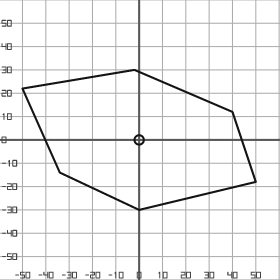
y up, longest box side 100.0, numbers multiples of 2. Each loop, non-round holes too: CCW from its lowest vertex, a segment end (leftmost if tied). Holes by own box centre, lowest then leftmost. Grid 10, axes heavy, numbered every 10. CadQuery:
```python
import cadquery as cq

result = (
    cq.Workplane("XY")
    .moveTo(0.0, -30.0)
    .lineTo(50.0, -18.0)
    .lineTo(40.0, 12.0)
    .lineTo(-2.0, 30.0)
    .lineTo(-50.0, 22.0)
    .lineTo(-34.0, -14.0)
    .close()
    .moveTo(0.0, 0.0)
    .circle(2.0)
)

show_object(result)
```